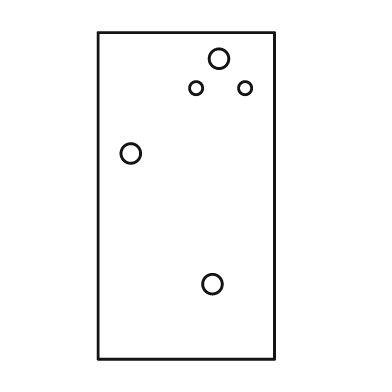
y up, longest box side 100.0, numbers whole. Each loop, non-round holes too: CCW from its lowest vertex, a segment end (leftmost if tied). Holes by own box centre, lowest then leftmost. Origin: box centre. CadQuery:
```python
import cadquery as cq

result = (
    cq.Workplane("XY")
    .moveTo(-27.0, -50.0)
    .lineTo(27.0, -50.0)
    .lineTo(27.0, 50.0)
    .lineTo(-27.0, 50.0)
    .close()
    .moveTo(8.0, -27.0)
    .circle(3.0)
    .moveTo(-17.0, 13.0)
    .circle(3.0)
    .moveTo(3.0, 33.0)
    .circle(2.0)
    .moveTo(18.0, 33.0)
    .circle(2.0)
    .moveTo(10.0, 42.0)
    .circle(3.0)
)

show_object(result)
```